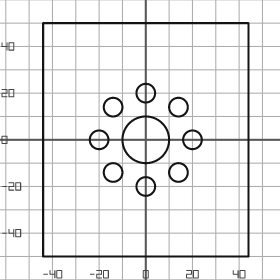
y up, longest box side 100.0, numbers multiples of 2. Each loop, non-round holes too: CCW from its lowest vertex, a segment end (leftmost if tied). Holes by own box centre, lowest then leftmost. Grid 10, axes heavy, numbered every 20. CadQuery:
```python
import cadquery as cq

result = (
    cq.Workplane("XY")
    .moveTo(-44.0, -50.0)
    .lineTo(44.0, -50.0)
    .lineTo(44.0, 50.0)
    .lineTo(-44.0, 50.0)
    .close()
    .moveTo(0.0, -20.0)
    .circle(4.0)
    .moveTo(-14.0, -14.0)
    .circle(4.0)
    .moveTo(14.0, -14.0)
    .circle(4.0)
    .moveTo(-20.0, 0.0)
    .circle(4.0)
    .moveTo(0.0, 0.0)
    .circle(10.0)
    .moveTo(20.0, 0.0)
    .circle(4.0)
    .moveTo(-14.0, 14.0)
    .circle(4.0)
    .moveTo(14.0, 14.0)
    .circle(4.0)
    .moveTo(0.0, 20.0)
    .circle(4.0)
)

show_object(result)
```